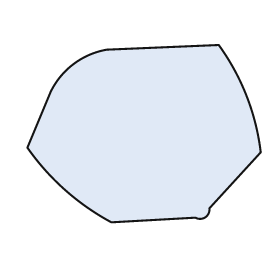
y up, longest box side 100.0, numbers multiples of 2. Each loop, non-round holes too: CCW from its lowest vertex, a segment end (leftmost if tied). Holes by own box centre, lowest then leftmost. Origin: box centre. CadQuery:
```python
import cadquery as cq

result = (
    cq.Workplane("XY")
    .moveTo(-14.0, -38.0)
    .lineTo(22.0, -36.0)
    .threePointArc((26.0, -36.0), (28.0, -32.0))
    .lineTo(50.0, -8.0)
    .threePointArc((44.0, 16.0), (32.0, 38.0))
    .lineTo(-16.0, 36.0)
    .threePointArc((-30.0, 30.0), (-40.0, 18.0))
    .lineTo(-50.0, -6.0)
    .threePointArc((-34.0, -24.0), (-14.0, -38.0))
    .close()
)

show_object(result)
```